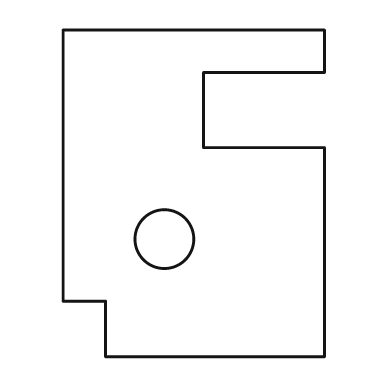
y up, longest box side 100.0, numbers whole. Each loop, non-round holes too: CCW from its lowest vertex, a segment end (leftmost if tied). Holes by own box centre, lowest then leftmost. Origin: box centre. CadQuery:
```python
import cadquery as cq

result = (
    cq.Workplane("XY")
    .moveTo(-27.0, -50.0)
    .lineTo(40.0, -50.0)
    .lineTo(40.0, 14.0)
    .lineTo(3.0, 14.0)
    .lineTo(3.0, 37.0)
    .lineTo(40.0, 37.0)
    .lineTo(40.0, 50.0)
    .lineTo(-40.0, 50.0)
    .lineTo(-40.0, -33.0)
    .lineTo(-27.0, -33.0)
    .close()
    .moveTo(-9.0, -14.0)
    .circle(9.0)
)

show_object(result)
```